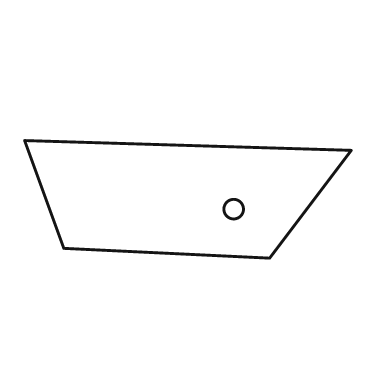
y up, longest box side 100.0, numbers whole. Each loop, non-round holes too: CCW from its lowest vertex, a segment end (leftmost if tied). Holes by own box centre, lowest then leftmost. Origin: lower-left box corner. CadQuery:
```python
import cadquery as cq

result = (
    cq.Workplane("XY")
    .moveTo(75.0, 0.0)
    .lineTo(100.0, 33.0)
    .lineTo(0.0, 36.0)
    .lineTo(12.0, 3.0)
    .close()
    .moveTo(64.0, 15.0)
    .circle(3.0)
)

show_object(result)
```